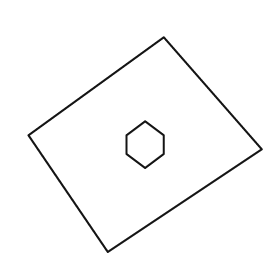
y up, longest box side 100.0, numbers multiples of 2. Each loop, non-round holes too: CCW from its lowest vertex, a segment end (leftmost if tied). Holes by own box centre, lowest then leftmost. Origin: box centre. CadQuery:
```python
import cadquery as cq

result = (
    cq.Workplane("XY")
    .moveTo(-16.0, -46.0)
    .lineTo(50.0, -2.0)
    .lineTo(8.0, 46.0)
    .lineTo(-50.0, 4.0)
    .close()
    .moveTo(0.0, -10.0)
    .lineTo(8.0, -4.0)
    .lineTo(8.0, 4.0)
    .lineTo(0.0, 10.0)
    .lineTo(-8.0, 4.0)
    .lineTo(-8.0, -4.0)
    .close()
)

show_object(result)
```